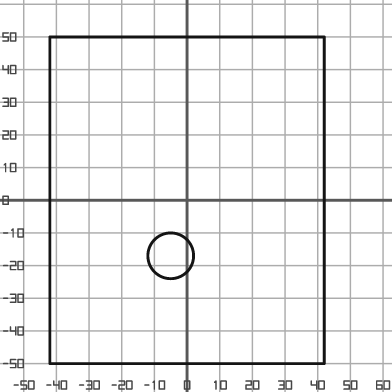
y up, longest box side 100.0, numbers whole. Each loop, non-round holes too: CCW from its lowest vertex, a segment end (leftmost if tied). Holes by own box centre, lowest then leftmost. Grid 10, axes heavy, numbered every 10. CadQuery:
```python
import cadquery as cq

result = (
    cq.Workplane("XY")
    .moveTo(-42.0, -50.0)
    .lineTo(42.0, -50.0)
    .lineTo(42.0, 50.0)
    .lineTo(-42.0, 50.0)
    .close()
    .moveTo(-5.0, -17.0)
    .circle(7.0)
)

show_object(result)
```